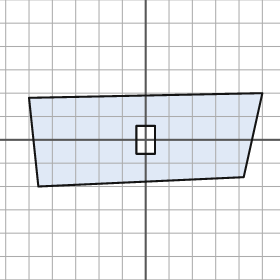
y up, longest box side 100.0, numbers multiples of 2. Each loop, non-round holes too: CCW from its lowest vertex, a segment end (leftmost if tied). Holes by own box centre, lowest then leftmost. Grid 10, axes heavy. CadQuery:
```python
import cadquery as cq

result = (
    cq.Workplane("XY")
    .moveTo(-46.0, -20.0)
    .lineTo(42.0, -16.0)
    .lineTo(50.0, 20.0)
    .lineTo(-50.0, 18.0)
    .close()
    .moveTo(-4.0, -6.0)
    .lineTo(4.0, -6.0)
    .lineTo(4.0, 6.0)
    .lineTo(-4.0, 6.0)
    .close()
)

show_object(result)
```